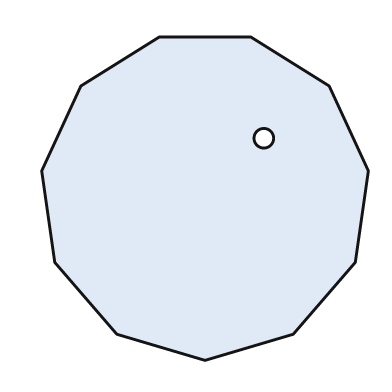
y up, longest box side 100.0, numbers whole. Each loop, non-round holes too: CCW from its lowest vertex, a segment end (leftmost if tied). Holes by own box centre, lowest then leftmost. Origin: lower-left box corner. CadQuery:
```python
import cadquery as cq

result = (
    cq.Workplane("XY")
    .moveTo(50.0, 0.0)
    .lineTo(77.0, 8.0)
    .lineTo(96.0, 30.0)
    .lineTo(100.0, 58.0)
    .lineTo(88.0, 84.0)
    .lineTo(64.0, 99.0)
    .lineTo(36.0, 99.0)
    .lineTo(12.0, 84.0)
    .lineTo(0.0, 58.0)
    .lineTo(4.0, 30.0)
    .lineTo(23.0, 8.0)
    .close()
    .moveTo(68.0, 68.0)
    .circle(3.0)
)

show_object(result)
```